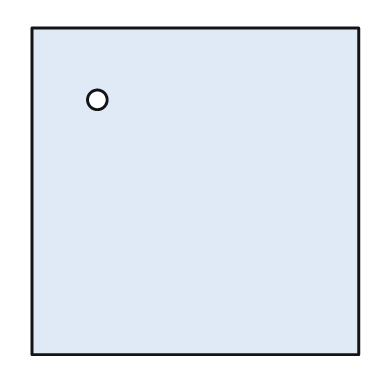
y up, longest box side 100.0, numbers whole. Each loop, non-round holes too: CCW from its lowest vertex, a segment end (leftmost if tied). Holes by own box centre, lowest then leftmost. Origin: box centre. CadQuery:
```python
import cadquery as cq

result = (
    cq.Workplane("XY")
    .moveTo(-50.0, -50.0)
    .lineTo(50.0, -50.0)
    .lineTo(50.0, 50.0)
    .lineTo(-50.0, 50.0)
    .close()
    .moveTo(-30.0, 28.0)
    .circle(3.0)
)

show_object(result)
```